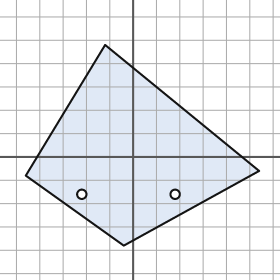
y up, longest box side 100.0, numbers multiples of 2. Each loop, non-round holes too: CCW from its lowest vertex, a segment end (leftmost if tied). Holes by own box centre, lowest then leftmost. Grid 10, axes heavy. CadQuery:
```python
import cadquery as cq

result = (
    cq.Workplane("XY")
    .moveTo(-4.0, -38.0)
    .lineTo(54.0, -6.0)
    .lineTo(-12.0, 48.0)
    .lineTo(-46.0, -8.0)
    .close()
    .moveTo(-22.0, -16.0)
    .circle(2.0)
    .moveTo(18.0, -16.0)
    .circle(2.0)
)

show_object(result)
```